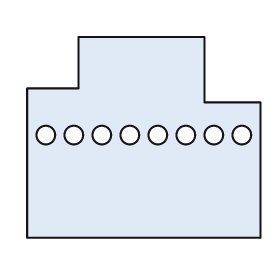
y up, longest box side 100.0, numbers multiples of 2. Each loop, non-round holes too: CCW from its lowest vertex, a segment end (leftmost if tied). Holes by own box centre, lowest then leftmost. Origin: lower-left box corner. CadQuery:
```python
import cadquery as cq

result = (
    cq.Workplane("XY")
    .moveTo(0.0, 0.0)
    .lineTo(100.0, 0.0)
    .lineTo(100.0, 58.0)
    .lineTo(76.0, 58.0)
    .lineTo(76.0, 86.0)
    .lineTo(22.0, 86.0)
    .lineTo(22.0, 64.0)
    .lineTo(0.0, 64.0)
    .close()
    .moveTo(8.0, 44.0)
    .circle(4.0)
    .moveTo(20.0, 44.0)
    .circle(4.0)
    .moveTo(32.0, 44.0)
    .circle(4.0)
    .moveTo(44.0, 44.0)
    .circle(4.0)
    .moveTo(56.0, 44.0)
    .circle(4.0)
    .moveTo(68.0, 44.0)
    .circle(4.0)
    .moveTo(80.0, 44.0)
    .circle(4.0)
    .moveTo(92.0, 44.0)
    .circle(4.0)
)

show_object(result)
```